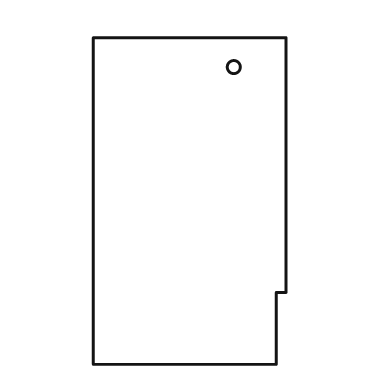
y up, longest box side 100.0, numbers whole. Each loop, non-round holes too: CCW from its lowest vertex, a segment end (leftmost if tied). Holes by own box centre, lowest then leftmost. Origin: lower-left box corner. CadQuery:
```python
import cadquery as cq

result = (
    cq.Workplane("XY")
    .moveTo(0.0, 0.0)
    .lineTo(56.0, 0.0)
    .lineTo(56.0, 22.0)
    .lineTo(59.0, 22.0)
    .lineTo(59.0, 100.0)
    .lineTo(0.0, 100.0)
    .close()
    .moveTo(43.0, 91.0)
    .circle(2.0)
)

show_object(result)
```